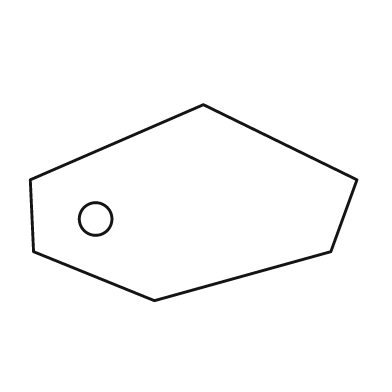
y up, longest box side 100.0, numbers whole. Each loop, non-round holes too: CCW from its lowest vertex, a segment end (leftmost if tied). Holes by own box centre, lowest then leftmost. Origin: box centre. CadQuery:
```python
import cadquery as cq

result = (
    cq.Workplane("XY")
    .moveTo(-12.0, -30.0)
    .lineTo(42.0, -15.0)
    .lineTo(50.0, 7.0)
    .lineTo(3.0, 30.0)
    .lineTo(-50.0, 7.0)
    .lineTo(-49.0, -15.0)
    .close()
    .moveTo(-30.0, -5.0)
    .circle(5.0)
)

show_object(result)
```